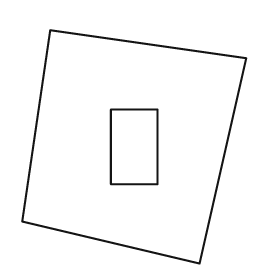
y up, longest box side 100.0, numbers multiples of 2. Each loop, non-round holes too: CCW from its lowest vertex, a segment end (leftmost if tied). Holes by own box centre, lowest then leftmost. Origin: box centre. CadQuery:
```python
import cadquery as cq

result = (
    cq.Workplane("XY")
    .moveTo(28.0, -50.0)
    .lineTo(48.0, 38.0)
    .lineTo(-36.0, 50.0)
    .lineTo(-48.0, -32.0)
    .close()
    .moveTo(-10.0, -16.0)
    .lineTo(10.0, -16.0)
    .lineTo(10.0, 16.0)
    .lineTo(-10.0, 16.0)
    .close()
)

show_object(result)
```